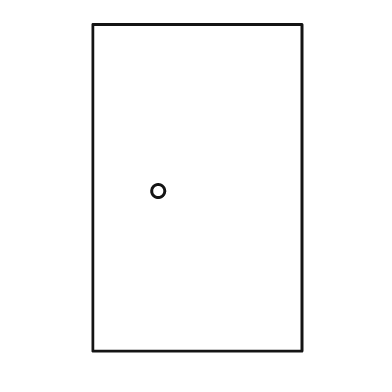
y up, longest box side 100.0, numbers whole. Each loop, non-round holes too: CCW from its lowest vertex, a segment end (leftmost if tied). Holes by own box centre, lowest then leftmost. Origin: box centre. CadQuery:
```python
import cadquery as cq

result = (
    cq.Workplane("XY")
    .moveTo(-32.0, -50.0)
    .lineTo(32.0, -50.0)
    .lineTo(32.0, 50.0)
    .lineTo(-32.0, 50.0)
    .close()
    .moveTo(-12.0, -1.0)
    .circle(2.0)
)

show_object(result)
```